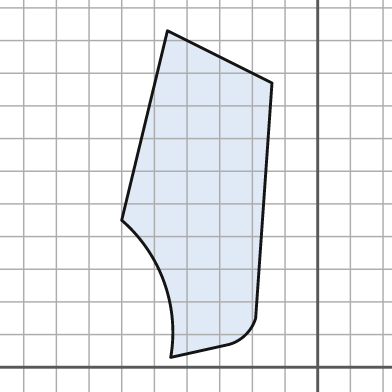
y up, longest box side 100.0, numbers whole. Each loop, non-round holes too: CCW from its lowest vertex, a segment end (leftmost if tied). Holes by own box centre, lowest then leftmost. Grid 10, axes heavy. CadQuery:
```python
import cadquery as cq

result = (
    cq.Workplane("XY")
    .moveTo(-45.0, 3.0)
    .lineTo(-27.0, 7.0)
    .threePointArc((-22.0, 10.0), (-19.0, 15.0))
    .lineTo(-14.0, 87.0)
    .lineTo(-46.0, 103.0)
    .lineTo(-60.0, 45.0)
    .threePointArc((-47.0, 26.0), (-45.0, 3.0))
    .close()
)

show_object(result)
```